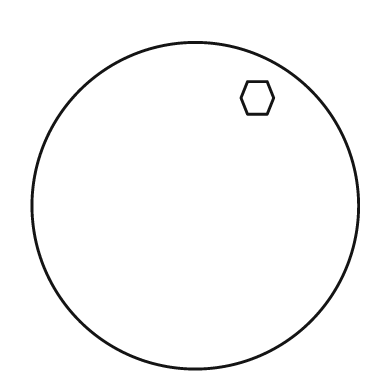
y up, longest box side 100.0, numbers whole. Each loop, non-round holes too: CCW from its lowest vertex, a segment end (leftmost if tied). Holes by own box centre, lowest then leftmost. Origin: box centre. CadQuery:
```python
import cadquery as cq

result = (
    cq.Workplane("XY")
    .moveTo(0.0, 0.0)
    .circle(50.0)
    .moveTo(16.0, 28.0)
    .lineTo(22.0, 28.0)
    .lineTo(24.0, 33.0)
    .lineTo(22.0, 38.0)
    .lineTo(16.0, 38.0)
    .lineTo(14.0, 33.0)
    .close()
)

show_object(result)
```